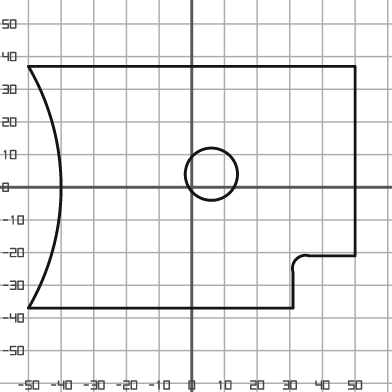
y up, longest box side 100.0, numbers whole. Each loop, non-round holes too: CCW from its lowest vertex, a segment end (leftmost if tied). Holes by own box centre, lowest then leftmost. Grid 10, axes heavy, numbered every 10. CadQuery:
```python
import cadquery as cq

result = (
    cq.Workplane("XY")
    .moveTo(-50.0, -37.0)
    .lineTo(31.0, -37.0)
    .lineTo(31.0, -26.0)
    .threePointArc((32.0, -22.0), (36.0, -21.0))
    .lineTo(50.0, -21.0)
    .lineTo(50.0, 37.0)
    .lineTo(-50.0, 37.0)
    .threePointArc((-40.0, 0.0), (-50.0, -37.0))
    .close()
    .moveTo(6.0, 4.0)
    .circle(8.0)
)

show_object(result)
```